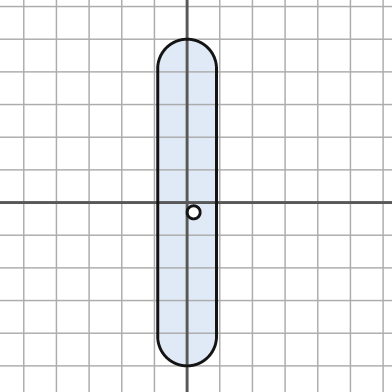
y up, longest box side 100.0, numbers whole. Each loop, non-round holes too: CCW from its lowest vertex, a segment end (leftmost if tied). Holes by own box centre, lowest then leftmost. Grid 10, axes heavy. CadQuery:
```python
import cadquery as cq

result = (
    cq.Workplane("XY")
    .moveTo(-9.0, -41.0)
    .threePointArc((0.0, -50.0), (9.0, -41.0))
    .lineTo(9.0, 41.0)
    .threePointArc((0.0, 50.0), (-9.0, 41.0))
    .close()
    .moveTo(2.0, -3.0)
    .circle(2.0)
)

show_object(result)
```